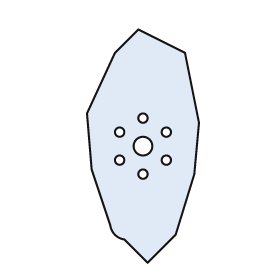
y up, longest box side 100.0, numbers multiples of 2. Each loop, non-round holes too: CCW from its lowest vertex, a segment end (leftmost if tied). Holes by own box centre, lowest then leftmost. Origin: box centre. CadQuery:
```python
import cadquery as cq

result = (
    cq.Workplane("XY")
    .moveTo(2.0, -50.0)
    .lineTo(14.0, -38.0)
    .lineTo(22.0, -12.0)
    .lineTo(24.0, 10.0)
    .lineTo(18.0, 40.0)
    .lineTo(-2.0, 50.0)
    .lineTo(-12.0, 40.0)
    .lineTo(-24.0, 14.0)
    .lineTo(-22.0, -10.0)
    .lineTo(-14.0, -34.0)
    .threePointArc((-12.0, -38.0), (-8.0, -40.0))
    .close()
    .moveTo(0.0, -12.0)
    .circle(2.0)
    .moveTo(-10.0, -6.0)
    .circle(2.0)
    .moveTo(10.0, -6.0)
    .circle(2.0)
    .moveTo(0.0, 0.0)
    .circle(4.0)
    .moveTo(-10.0, 6.0)
    .circle(2.0)
    .moveTo(10.0, 6.0)
    .circle(2.0)
    .moveTo(0.0, 12.0)
    .circle(2.0)
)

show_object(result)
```